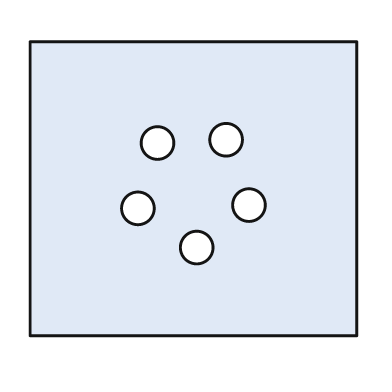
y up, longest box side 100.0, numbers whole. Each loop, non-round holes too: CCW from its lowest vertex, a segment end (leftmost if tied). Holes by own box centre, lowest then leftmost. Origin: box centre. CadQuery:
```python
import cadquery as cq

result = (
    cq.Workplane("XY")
    .moveTo(-50.0, -45.0)
    .lineTo(50.0, -45.0)
    .lineTo(50.0, 45.0)
    .lineTo(-50.0, 45.0)
    .close()
    .moveTo(1.0, -18.0)
    .circle(5.0)
    .moveTo(-17.0, -6.0)
    .circle(5.0)
    .moveTo(17.0, -5.0)
    .circle(5.0)
    .moveTo(-11.0, 14.0)
    .circle(5.0)
    .moveTo(10.0, 15.0)
    .circle(5.0)
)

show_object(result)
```